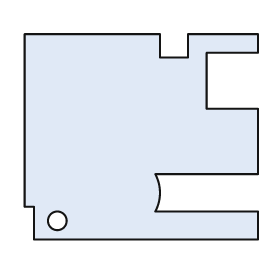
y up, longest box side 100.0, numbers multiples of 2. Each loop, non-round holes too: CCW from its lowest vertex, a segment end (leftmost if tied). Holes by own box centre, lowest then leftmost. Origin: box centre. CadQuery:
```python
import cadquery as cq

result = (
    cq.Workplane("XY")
    .moveTo(-46.0, -44.0)
    .lineTo(50.0, -44.0)
    .lineTo(50.0, -32.0)
    .lineTo(6.0, -32.0)
    .threePointArc((8.0, -24.0), (6.0, -16.0))
    .lineTo(50.0, -16.0)
    .lineTo(50.0, 12.0)
    .lineTo(28.0, 12.0)
    .lineTo(28.0, 36.0)
    .lineTo(50.0, 36.0)
    .lineTo(50.0, 44.0)
    .lineTo(20.0, 44.0)
    .lineTo(20.0, 34.0)
    .lineTo(8.0, 34.0)
    .lineTo(8.0, 44.0)
    .lineTo(-50.0, 44.0)
    .lineTo(-50.0, -30.0)
    .lineTo(-46.0, -30.0)
    .close()
    .moveTo(-36.0, -36.0)
    .circle(4.0)
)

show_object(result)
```